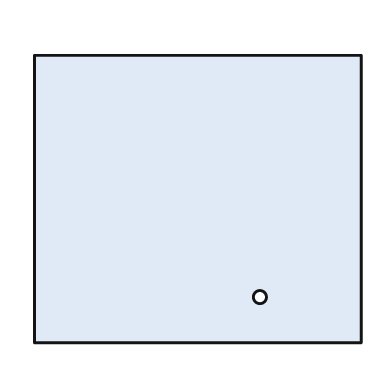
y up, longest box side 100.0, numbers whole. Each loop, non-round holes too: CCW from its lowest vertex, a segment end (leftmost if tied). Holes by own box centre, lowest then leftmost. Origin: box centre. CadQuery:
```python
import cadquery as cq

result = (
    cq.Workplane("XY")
    .moveTo(-50.0, -44.0)
    .lineTo(50.0, -44.0)
    .lineTo(50.0, 44.0)
    .lineTo(-50.0, 44.0)
    .close()
    .moveTo(19.0, -30.0)
    .circle(2.0)
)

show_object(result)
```